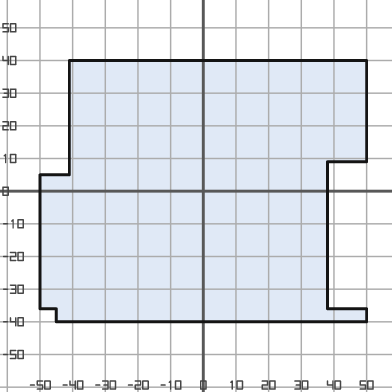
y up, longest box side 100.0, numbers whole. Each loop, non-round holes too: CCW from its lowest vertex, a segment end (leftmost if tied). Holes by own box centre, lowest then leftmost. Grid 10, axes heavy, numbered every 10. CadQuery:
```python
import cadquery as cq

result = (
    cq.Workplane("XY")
    .moveTo(-45.0, -40.0)
    .lineTo(50.0, -40.0)
    .lineTo(50.0, -36.0)
    .lineTo(38.0, -36.0)
    .lineTo(38.0, 9.0)
    .lineTo(50.0, 9.0)
    .lineTo(50.0, 40.0)
    .lineTo(-41.0, 40.0)
    .lineTo(-41.0, 5.0)
    .lineTo(-50.0, 5.0)
    .lineTo(-50.0, -36.0)
    .lineTo(-45.0, -36.0)
    .close()
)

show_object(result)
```